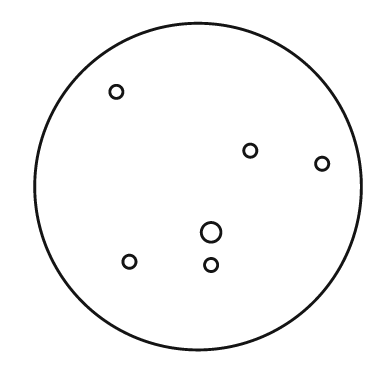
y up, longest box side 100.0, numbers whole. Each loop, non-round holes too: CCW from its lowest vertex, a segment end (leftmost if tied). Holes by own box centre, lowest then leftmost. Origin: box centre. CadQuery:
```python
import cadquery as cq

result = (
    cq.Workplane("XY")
    .moveTo(0.0, 0.0)
    .circle(50.0)
    .moveTo(4.0, -24.0)
    .circle(2.0)
    .moveTo(-21.0, -23.0)
    .circle(2.0)
    .moveTo(4.0, -14.0)
    .circle(3.0)
    .moveTo(38.0, 7.0)
    .circle(2.0)
    .moveTo(16.0, 11.0)
    .circle(2.0)
    .moveTo(-25.0, 29.0)
    .circle(2.0)
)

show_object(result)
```